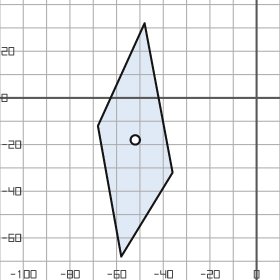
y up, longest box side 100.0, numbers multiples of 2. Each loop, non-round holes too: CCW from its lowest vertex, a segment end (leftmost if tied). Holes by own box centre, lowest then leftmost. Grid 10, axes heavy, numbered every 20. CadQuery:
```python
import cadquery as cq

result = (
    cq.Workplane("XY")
    .moveTo(-58.0, -68.0)
    .lineTo(-36.0, -32.0)
    .lineTo(-48.0, 32.0)
    .lineTo(-68.0, -12.0)
    .close()
    .moveTo(-52.0, -18.0)
    .circle(2.0)
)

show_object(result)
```